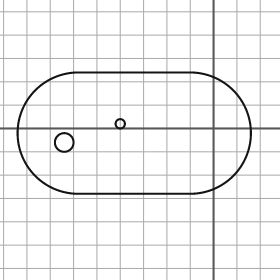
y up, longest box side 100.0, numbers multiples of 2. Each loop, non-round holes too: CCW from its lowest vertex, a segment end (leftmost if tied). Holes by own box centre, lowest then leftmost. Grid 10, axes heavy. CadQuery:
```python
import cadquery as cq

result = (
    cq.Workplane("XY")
    .moveTo(-58.0, -28.0)
    .lineTo(-10.0, -28.0)
    .threePointArc((16.0, -2.0), (-10.0, 24.0))
    .lineTo(-58.0, 24.0)
    .threePointArc((-84.0, -2.0), (-58.0, -28.0))
    .close()
    .moveTo(-64.0, -6.0)
    .circle(4.0)
    .moveTo(-40.0, 2.0)
    .circle(2.0)
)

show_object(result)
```